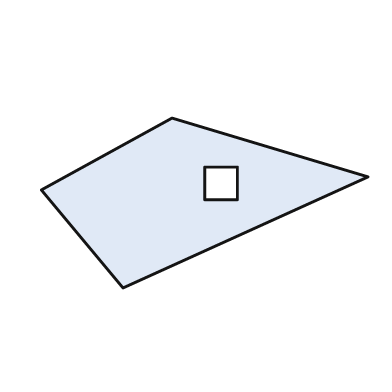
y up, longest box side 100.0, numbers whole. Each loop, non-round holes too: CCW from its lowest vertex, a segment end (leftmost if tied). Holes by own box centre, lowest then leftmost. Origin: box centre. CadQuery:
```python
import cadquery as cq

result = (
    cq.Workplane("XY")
    .moveTo(-25.0, -26.0)
    .lineTo(50.0, 8.0)
    .lineTo(-10.0, 26.0)
    .lineTo(-50.0, 4.0)
    .close()
    .moveTo(0.0, 1.0)
    .lineTo(10.0, 1.0)
    .lineTo(10.0, 11.0)
    .lineTo(0.0, 11.0)
    .close()
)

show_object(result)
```